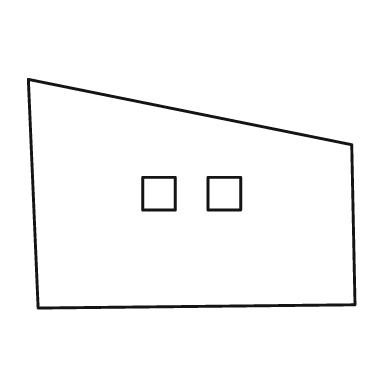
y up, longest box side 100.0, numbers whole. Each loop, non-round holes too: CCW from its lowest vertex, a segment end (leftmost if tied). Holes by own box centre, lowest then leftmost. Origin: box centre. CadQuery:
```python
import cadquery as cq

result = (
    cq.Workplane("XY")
    .moveTo(-47.0, -35.0)
    .lineTo(50.0, -34.0)
    .lineTo(49.0, 15.0)
    .lineTo(-50.0, 35.0)
    .close()
    .moveTo(-15.0, -5.0)
    .lineTo(-5.0, -5.0)
    .lineTo(-5.0, 5.0)
    .lineTo(-15.0, 5.0)
    .close()
    .moveTo(5.0, -5.0)
    .lineTo(15.0, -5.0)
    .lineTo(15.0, 5.0)
    .lineTo(5.0, 5.0)
    .close()
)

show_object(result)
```